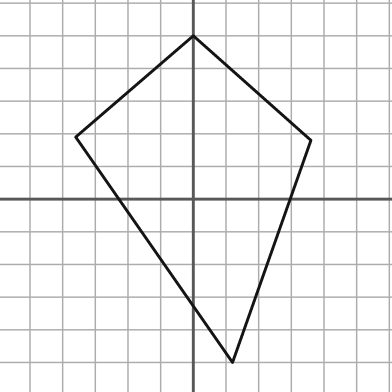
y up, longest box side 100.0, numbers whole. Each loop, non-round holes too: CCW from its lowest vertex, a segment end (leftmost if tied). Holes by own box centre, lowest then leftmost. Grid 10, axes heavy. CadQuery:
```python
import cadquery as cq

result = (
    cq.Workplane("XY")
    .moveTo(12.0, -50.0)
    .lineTo(36.0, 18.0)
    .lineTo(0.0, 50.0)
    .lineTo(-36.0, 19.0)
    .close()
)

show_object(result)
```